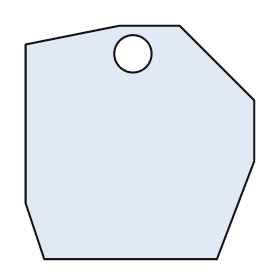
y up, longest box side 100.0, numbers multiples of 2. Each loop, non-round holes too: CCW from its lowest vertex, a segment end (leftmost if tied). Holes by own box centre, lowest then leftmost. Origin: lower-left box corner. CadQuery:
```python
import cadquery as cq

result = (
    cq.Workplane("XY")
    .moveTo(8.0, 0.0)
    .lineTo(82.0, 0.0)
    .lineTo(98.0, 42.0)
    .lineTo(98.0, 68.0)
    .lineTo(66.0, 100.0)
    .lineTo(40.0, 100.0)
    .lineTo(0.0, 92.0)
    .lineTo(0.0, 24.0)
    .close()
    .moveTo(46.0, 88.0)
    .circle(8.0)
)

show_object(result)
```